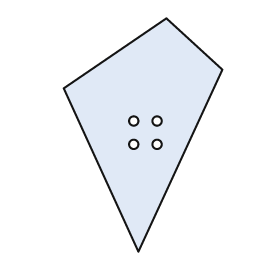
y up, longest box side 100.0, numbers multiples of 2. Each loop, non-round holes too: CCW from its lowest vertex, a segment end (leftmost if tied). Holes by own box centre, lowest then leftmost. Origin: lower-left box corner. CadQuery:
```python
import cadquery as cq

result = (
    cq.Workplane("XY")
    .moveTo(32.0, 0.0)
    .lineTo(68.0, 78.0)
    .lineTo(44.0, 100.0)
    .lineTo(0.0, 70.0)
    .close()
    .moveTo(30.0, 46.0)
    .circle(2.0)
    .moveTo(40.0, 46.0)
    .circle(2.0)
    .moveTo(30.0, 56.0)
    .circle(2.0)
    .moveTo(40.0, 56.0)
    .circle(2.0)
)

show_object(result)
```